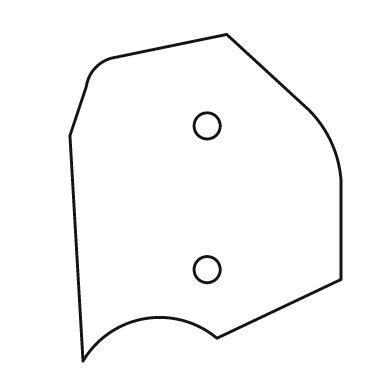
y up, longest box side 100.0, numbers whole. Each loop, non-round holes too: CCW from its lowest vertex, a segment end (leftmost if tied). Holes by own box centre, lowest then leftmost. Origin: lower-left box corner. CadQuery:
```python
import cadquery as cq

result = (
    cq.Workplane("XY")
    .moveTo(4.0, 0.0)
    .threePointArc((23.0, 13.0), (45.0, 7.0))
    .lineTo(83.0, 25.0)
    .lineTo(83.0, 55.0)
    .threePointArc((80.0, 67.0), (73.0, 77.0))
    .lineTo(48.0, 100.0)
    .lineTo(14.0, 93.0)
    .threePointArc((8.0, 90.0), (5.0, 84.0))
    .lineTo(0.0, 69.0)
    .close()
    .moveTo(42.0, 28.0)
    .circle(4.0)
    .moveTo(42.0, 72.0)
    .circle(4.0)
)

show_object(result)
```